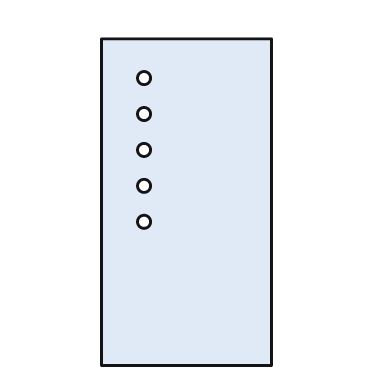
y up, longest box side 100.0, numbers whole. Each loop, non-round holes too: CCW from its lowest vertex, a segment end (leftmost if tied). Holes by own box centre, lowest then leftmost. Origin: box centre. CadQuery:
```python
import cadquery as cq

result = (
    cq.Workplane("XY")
    .moveTo(-26.0, -50.0)
    .lineTo(26.0, -50.0)
    .lineTo(26.0, 50.0)
    .lineTo(-26.0, 50.0)
    .close()
    .moveTo(-13.0, -6.0)
    .circle(2.0)
    .moveTo(-13.0, 5.0)
    .circle(2.0)
    .moveTo(-13.0, 16.0)
    .circle(2.0)
    .moveTo(-13.0, 27.0)
    .circle(2.0)
    .moveTo(-13.0, 38.0)
    .circle(2.0)
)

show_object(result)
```